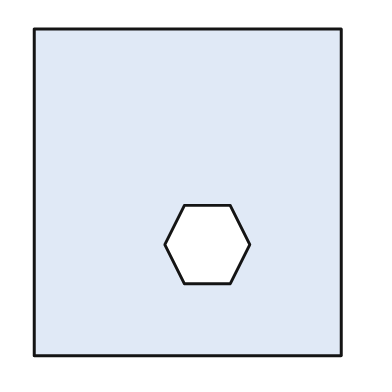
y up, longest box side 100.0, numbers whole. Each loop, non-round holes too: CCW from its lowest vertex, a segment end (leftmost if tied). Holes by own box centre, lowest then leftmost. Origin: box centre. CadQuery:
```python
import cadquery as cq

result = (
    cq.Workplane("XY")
    .moveTo(-47.0, -50.0)
    .lineTo(47.0, -50.0)
    .lineTo(47.0, 50.0)
    .lineTo(-47.0, 50.0)
    .close()
    .moveTo(-1.0, -28.0)
    .lineTo(13.0, -28.0)
    .lineTo(19.0, -16.0)
    .lineTo(13.0, -4.0)
    .lineTo(-1.0, -4.0)
    .lineTo(-7.0, -16.0)
    .close()
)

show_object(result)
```